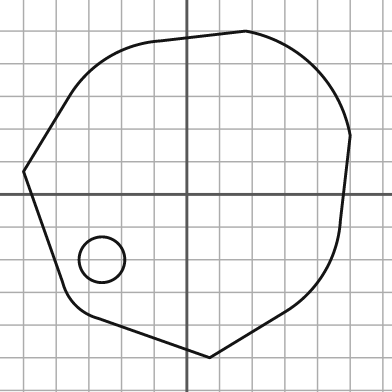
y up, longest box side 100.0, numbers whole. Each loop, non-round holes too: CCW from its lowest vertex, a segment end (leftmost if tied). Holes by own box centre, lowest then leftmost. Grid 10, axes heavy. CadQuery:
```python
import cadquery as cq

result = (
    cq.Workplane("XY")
    .moveTo(7.0, -50.0)
    .lineTo(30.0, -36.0)
    .threePointArc((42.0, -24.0), (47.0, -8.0))
    .lineTo(50.0, 18.0)
    .threePointArc((39.0, 39.0), (18.0, 50.0))
    .lineTo(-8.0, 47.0)
    .threePointArc((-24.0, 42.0), (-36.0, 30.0))
    .lineTo(-50.0, 7.0)
    .lineTo(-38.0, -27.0)
    .threePointArc((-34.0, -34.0), (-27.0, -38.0))
    .close()
    .moveTo(-26.0, -20.0)
    .circle(7.0)
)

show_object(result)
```